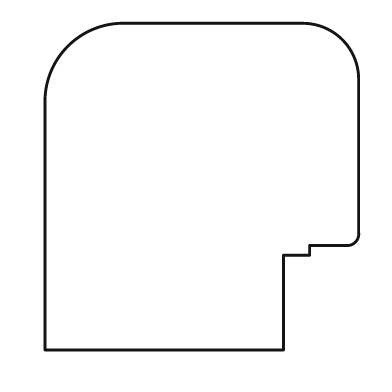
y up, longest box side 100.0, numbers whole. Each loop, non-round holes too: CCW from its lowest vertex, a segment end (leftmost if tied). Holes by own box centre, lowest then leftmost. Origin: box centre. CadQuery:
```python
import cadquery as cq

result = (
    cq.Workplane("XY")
    .moveTo(-48.0, -50.0)
    .lineTo(25.0, -50.0)
    .lineTo(25.0, -21.0)
    .lineTo(33.0, -21.0)
    .lineTo(33.0, -18.0)
    .lineTo(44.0, -18.0)
    .threePointArc((47.0, -17.0), (48.0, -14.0))
    .lineTo(48.0, 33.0)
    .threePointArc((43.0, 45.0), (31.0, 50.0))
    .lineTo(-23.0, 50.0)
    .threePointArc((-41.0, 43.0), (-48.0, 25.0))
    .close()
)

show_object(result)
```